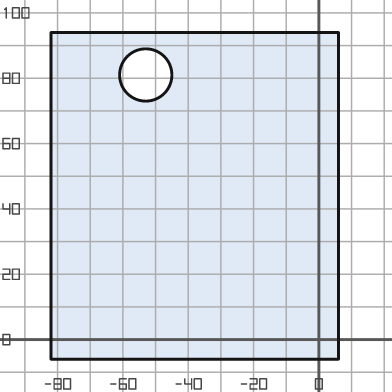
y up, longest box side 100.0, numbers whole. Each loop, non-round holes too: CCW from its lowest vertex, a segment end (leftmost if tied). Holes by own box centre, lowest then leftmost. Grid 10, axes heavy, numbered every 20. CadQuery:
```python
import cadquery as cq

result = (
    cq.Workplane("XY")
    .moveTo(-82.0, -6.0)
    .lineTo(6.0, -6.0)
    .lineTo(6.0, 94.0)
    .lineTo(-82.0, 94.0)
    .close()
    .moveTo(-53.0, 81.0)
    .circle(8.0)
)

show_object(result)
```